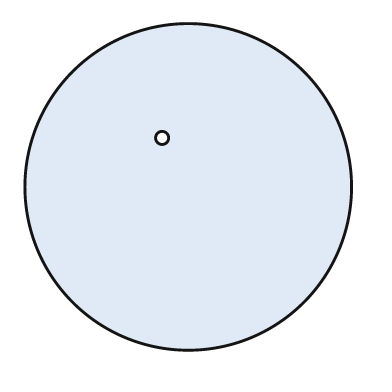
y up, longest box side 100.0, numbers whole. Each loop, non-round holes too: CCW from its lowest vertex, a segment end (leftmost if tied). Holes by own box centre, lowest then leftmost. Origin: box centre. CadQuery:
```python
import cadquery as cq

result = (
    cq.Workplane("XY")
    .moveTo(0.0, 0.0)
    .circle(50.0)
    .moveTo(-8.0, 15.0)
    .circle(2.0)
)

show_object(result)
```